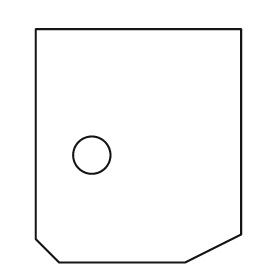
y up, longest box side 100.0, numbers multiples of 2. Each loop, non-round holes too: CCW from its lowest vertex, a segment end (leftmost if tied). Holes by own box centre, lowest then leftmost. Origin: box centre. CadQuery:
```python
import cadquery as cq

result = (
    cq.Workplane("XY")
    .moveTo(-34.0, -50.0)
    .lineTo(20.0, -50.0)
    .lineTo(44.0, -38.0)
    .lineTo(44.0, 50.0)
    .lineTo(-44.0, 50.0)
    .lineTo(-44.0, -40.0)
    .close()
    .moveTo(-20.0, -4.0)
    .circle(8.0)
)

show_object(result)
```